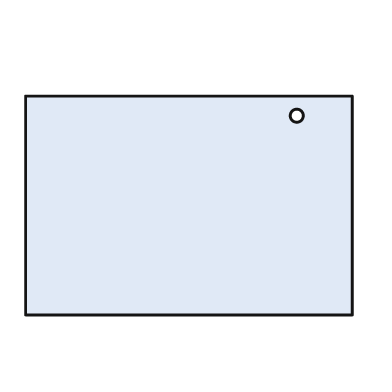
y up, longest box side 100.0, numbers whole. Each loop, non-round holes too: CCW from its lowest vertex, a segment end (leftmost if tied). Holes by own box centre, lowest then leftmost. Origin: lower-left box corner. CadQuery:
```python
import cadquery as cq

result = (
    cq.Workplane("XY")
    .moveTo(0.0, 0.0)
    .lineTo(100.0, 0.0)
    .lineTo(100.0, 67.0)
    .lineTo(0.0, 67.0)
    .close()
    .moveTo(83.0, 61.0)
    .circle(2.0)
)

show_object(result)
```